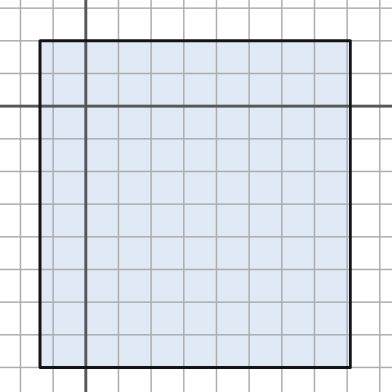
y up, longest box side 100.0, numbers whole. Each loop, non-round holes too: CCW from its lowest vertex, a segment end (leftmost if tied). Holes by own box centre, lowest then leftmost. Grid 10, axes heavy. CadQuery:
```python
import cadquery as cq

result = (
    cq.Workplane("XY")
    .moveTo(-14.0, -80.0)
    .lineTo(81.0, -80.0)
    .lineTo(81.0, 20.0)
    .lineTo(-14.0, 20.0)
    .close()
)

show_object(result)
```